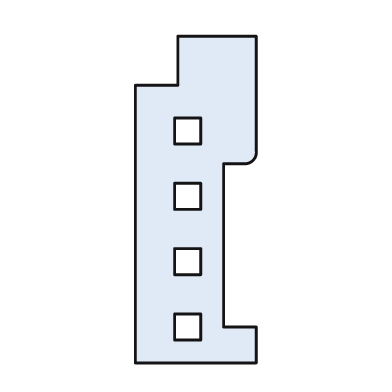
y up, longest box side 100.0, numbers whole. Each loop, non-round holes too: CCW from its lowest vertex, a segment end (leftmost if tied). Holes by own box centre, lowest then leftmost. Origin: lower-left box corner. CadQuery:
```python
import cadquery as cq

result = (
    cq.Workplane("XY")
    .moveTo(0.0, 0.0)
    .lineTo(37.0, 0.0)
    .lineTo(37.0, 11.0)
    .lineTo(27.0, 11.0)
    .lineTo(27.0, 61.0)
    .lineTo(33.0, 61.0)
    .threePointArc((36.0, 62.0), (37.0, 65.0))
    .lineTo(37.0, 100.0)
    .lineTo(13.0, 100.0)
    .lineTo(13.0, 85.0)
    .lineTo(0.0, 85.0)
    .close()
    .moveTo(12.0, 7.0)
    .lineTo(20.0, 7.0)
    .lineTo(20.0, 15.0)
    .lineTo(12.0, 15.0)
    .close()
    .moveTo(12.0, 27.0)
    .lineTo(20.0, 27.0)
    .lineTo(20.0, 35.0)
    .lineTo(12.0, 35.0)
    .close()
    .moveTo(12.0, 47.0)
    .lineTo(20.0, 47.0)
    .lineTo(20.0, 55.0)
    .lineTo(12.0, 55.0)
    .close()
    .moveTo(12.0, 67.0)
    .lineTo(20.0, 67.0)
    .lineTo(20.0, 75.0)
    .lineTo(12.0, 75.0)
    .close()
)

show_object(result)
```